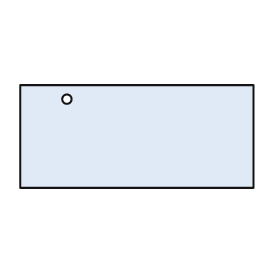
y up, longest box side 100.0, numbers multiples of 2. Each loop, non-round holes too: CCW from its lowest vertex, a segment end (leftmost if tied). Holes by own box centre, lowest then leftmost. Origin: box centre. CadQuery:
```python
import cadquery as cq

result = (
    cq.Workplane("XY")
    .moveTo(-50.0, -22.0)
    .lineTo(50.0, -22.0)
    .lineTo(50.0, 22.0)
    .lineTo(-50.0, 22.0)
    .close()
    .moveTo(-30.0, 16.0)
    .circle(2.0)
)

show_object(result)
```